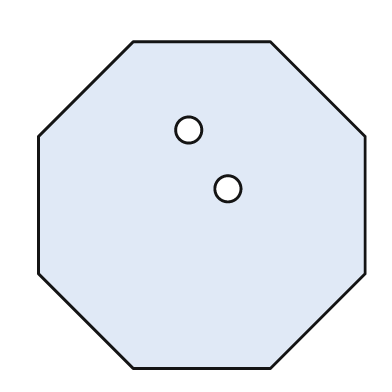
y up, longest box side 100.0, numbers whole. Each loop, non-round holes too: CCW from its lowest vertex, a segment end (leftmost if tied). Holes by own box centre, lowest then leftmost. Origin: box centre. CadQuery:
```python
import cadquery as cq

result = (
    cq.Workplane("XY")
    .moveTo(-21.0, -50.0)
    .lineTo(21.0, -50.0)
    .lineTo(50.0, -21.0)
    .lineTo(50.0, 21.0)
    .lineTo(21.0, 50.0)
    .lineTo(-21.0, 50.0)
    .lineTo(-50.0, 21.0)
    .lineTo(-50.0, -21.0)
    .close()
    .moveTo(8.0, 5.0)
    .circle(4.0)
    .moveTo(-4.0, 23.0)
    .circle(4.0)
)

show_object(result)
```